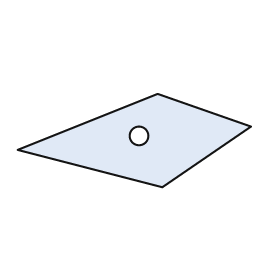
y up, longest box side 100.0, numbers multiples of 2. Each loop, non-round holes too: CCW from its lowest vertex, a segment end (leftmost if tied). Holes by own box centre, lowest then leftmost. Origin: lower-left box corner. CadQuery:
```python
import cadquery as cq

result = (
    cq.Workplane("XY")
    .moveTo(62.0, 0.0)
    .lineTo(100.0, 26.0)
    .lineTo(60.0, 40.0)
    .lineTo(0.0, 16.0)
    .close()
    .moveTo(52.0, 22.0)
    .circle(4.0)
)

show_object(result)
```